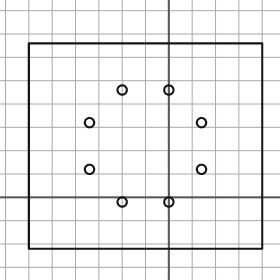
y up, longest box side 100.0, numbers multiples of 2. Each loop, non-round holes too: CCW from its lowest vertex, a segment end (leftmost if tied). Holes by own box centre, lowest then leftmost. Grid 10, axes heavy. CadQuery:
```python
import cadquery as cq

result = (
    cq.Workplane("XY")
    .moveTo(-60.0, -22.0)
    .lineTo(40.0, -22.0)
    .lineTo(40.0, 66.0)
    .lineTo(-60.0, 66.0)
    .close()
    .moveTo(-20.0, -2.0)
    .circle(2.0)
    .moveTo(0.0, -2.0)
    .circle(2.0)
    .moveTo(-34.0, 12.0)
    .circle(2.0)
    .moveTo(14.0, 12.0)
    .circle(2.0)
    .moveTo(-34.0, 32.0)
    .circle(2.0)
    .moveTo(14.0, 32.0)
    .circle(2.0)
    .moveTo(-20.0, 46.0)
    .circle(2.0)
    .moveTo(0.0, 46.0)
    .circle(2.0)
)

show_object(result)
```